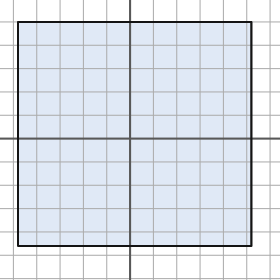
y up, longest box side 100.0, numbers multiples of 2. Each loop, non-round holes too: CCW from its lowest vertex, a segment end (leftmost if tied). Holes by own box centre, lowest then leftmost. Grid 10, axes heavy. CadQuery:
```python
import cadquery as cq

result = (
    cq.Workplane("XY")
    .moveTo(-48.0, -46.0)
    .lineTo(52.0, -46.0)
    .lineTo(52.0, 50.0)
    .lineTo(-48.0, 50.0)
    .close()
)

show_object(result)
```